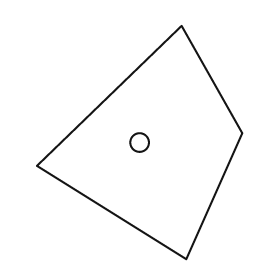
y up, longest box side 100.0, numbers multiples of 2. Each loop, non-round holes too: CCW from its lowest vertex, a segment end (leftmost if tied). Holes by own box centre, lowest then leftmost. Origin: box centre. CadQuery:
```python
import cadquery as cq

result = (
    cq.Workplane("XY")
    .moveTo(20.0, -50.0)
    .lineTo(44.0, 4.0)
    .lineTo(18.0, 50.0)
    .lineTo(-44.0, -10.0)
    .close()
    .moveTo(0.0, 0.0)
    .circle(4.0)
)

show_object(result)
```